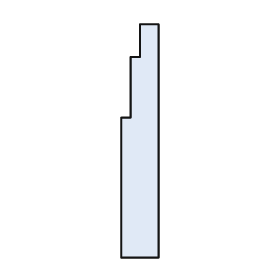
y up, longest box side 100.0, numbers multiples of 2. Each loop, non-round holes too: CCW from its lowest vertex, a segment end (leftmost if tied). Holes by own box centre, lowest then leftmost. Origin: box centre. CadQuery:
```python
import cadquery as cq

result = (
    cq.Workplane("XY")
    .moveTo(-8.0, -50.0)
    .lineTo(8.0, -50.0)
    .lineTo(8.0, 50.0)
    .lineTo(0.0, 50.0)
    .lineTo(0.0, 36.0)
    .lineTo(-4.0, 36.0)
    .lineTo(-4.0, 10.0)
    .lineTo(-8.0, 10.0)
    .close()
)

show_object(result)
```